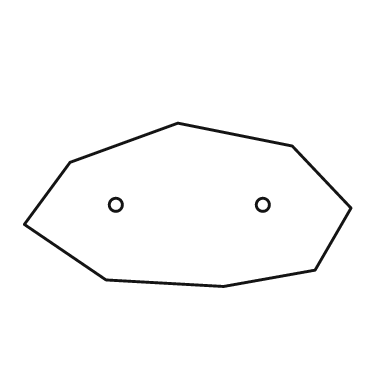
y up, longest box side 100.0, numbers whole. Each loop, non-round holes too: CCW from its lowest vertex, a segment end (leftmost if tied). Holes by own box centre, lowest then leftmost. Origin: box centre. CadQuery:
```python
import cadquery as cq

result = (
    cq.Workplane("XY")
    .moveTo(11.0, -25.0)
    .lineTo(39.0, -20.0)
    .lineTo(50.0, -1.0)
    .lineTo(32.0, 18.0)
    .lineTo(-3.0, 25.0)
    .lineTo(-36.0, 13.0)
    .lineTo(-50.0, -6.0)
    .lineTo(-25.0, -23.0)
    .close()
    .moveTo(-22.0, 0.0)
    .circle(2.0)
    .moveTo(23.0, 0.0)
    .circle(2.0)
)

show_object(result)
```